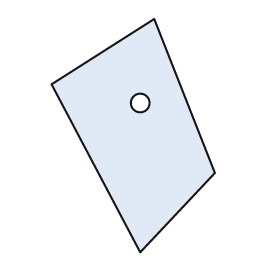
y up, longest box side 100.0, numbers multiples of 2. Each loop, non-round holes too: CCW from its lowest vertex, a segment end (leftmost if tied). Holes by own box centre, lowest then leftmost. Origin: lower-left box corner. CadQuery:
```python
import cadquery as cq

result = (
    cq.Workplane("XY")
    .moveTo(38.0, 0.0)
    .lineTo(70.0, 34.0)
    .lineTo(44.0, 100.0)
    .lineTo(0.0, 72.0)
    .close()
    .moveTo(38.0, 64.0)
    .circle(4.0)
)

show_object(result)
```